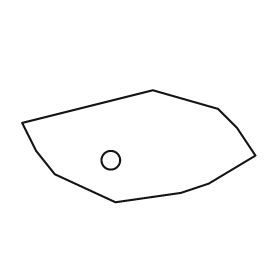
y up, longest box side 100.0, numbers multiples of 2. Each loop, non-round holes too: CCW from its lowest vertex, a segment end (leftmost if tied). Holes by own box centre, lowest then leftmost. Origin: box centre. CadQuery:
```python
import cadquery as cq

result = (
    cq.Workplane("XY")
    .moveTo(-10.0, -24.0)
    .lineTo(18.0, -20.0)
    .lineTo(30.0, -16.0)
    .lineTo(50.0, -4.0)
    .lineTo(42.0, 8.0)
    .lineTo(34.0, 16.0)
    .lineTo(6.0, 24.0)
    .lineTo(-50.0, 10.0)
    .lineTo(-44.0, -2.0)
    .lineTo(-36.0, -12.0)
    .close()
    .moveTo(-12.0, -6.0)
    .circle(4.0)
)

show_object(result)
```